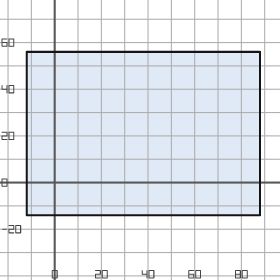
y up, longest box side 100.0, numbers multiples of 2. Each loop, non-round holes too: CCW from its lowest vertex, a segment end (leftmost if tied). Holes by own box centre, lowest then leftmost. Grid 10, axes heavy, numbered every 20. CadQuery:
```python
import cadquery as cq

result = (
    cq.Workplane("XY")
    .moveTo(-12.0, -14.0)
    .lineTo(88.0, -14.0)
    .lineTo(88.0, 56.0)
    .lineTo(-12.0, 56.0)
    .close()
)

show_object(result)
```